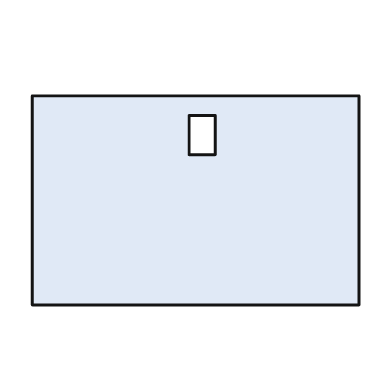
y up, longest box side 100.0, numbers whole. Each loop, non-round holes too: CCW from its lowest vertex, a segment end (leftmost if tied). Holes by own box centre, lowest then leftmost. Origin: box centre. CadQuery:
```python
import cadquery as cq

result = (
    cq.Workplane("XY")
    .moveTo(-50.0, -32.0)
    .lineTo(50.0, -32.0)
    .lineTo(50.0, 32.0)
    .lineTo(-50.0, 32.0)
    .close()
    .moveTo(-2.0, 14.0)
    .lineTo(6.0, 14.0)
    .lineTo(6.0, 26.0)
    .lineTo(-2.0, 26.0)
    .close()
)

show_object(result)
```